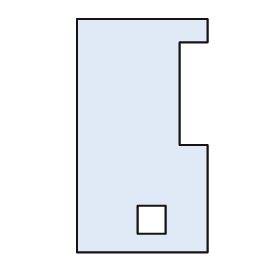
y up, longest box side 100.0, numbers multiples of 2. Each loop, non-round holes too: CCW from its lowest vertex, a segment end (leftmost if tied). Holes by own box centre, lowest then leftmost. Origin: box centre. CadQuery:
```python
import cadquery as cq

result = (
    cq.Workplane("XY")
    .moveTo(-28.0, -50.0)
    .lineTo(28.0, -50.0)
    .lineTo(28.0, -4.0)
    .lineTo(16.0, -4.0)
    .lineTo(16.0, 40.0)
    .lineTo(28.0, 40.0)
    .lineTo(28.0, 50.0)
    .lineTo(-28.0, 50.0)
    .close()
    .moveTo(-2.0, -42.0)
    .lineTo(10.0, -42.0)
    .lineTo(10.0, -30.0)
    .lineTo(-2.0, -30.0)
    .close()
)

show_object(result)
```